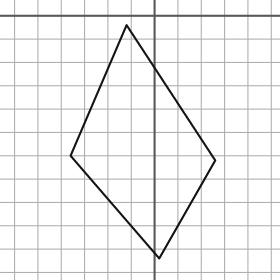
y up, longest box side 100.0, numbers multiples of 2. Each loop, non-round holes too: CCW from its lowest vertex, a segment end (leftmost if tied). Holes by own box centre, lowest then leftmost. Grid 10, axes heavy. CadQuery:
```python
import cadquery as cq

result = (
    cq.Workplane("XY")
    .moveTo(2.0, -104.0)
    .lineTo(26.0, -62.0)
    .lineTo(-12.0, -4.0)
    .lineTo(-36.0, -60.0)
    .close()
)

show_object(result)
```